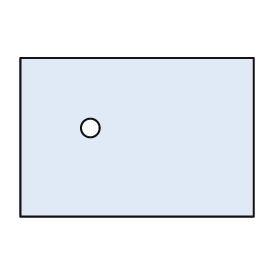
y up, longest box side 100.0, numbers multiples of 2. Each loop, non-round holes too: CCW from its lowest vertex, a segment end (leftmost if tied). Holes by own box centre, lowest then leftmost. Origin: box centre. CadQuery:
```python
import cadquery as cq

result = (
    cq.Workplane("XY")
    .moveTo(-50.0, -34.0)
    .lineTo(50.0, -34.0)
    .lineTo(50.0, 34.0)
    .lineTo(-50.0, 34.0)
    .close()
    .moveTo(-20.0, 4.0)
    .circle(4.0)
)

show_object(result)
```